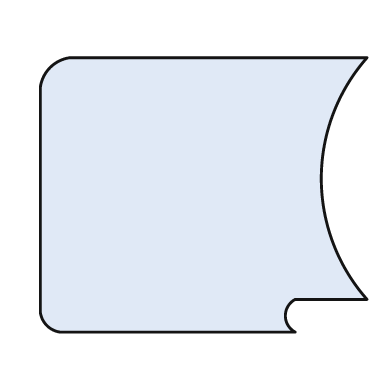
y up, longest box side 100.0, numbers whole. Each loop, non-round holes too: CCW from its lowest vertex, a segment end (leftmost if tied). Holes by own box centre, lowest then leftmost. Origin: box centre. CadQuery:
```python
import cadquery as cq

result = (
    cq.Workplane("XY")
    .moveTo(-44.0, -42.0)
    .lineTo(28.0, -42.0)
    .threePointArc((25.0, -37.0), (28.0, -32.0))
    .lineTo(50.0, -32.0)
    .threePointArc((36.0, 5.0), (50.0, 42.0))
    .lineTo(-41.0, 42.0)
    .threePointArc((-47.0, 39.0), (-50.0, 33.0))
    .lineTo(-50.0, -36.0)
    .threePointArc((-48.0, -40.0), (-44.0, -42.0))
    .close()
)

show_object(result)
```